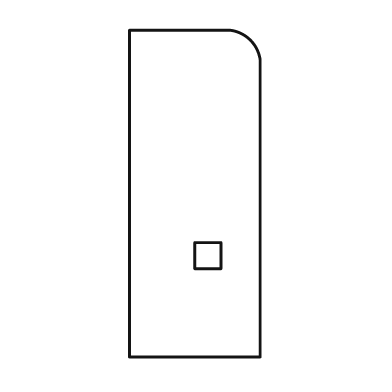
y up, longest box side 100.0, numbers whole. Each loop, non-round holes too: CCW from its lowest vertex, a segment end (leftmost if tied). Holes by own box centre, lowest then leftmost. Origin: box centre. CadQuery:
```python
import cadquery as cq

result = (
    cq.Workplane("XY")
    .moveTo(-20.0, -50.0)
    .lineTo(20.0, -50.0)
    .lineTo(20.0, 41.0)
    .threePointArc((17.0, 47.0), (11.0, 50.0))
    .lineTo(-20.0, 50.0)
    .close()
    .moveTo(0.0, -23.0)
    .lineTo(8.0, -23.0)
    .lineTo(8.0, -15.0)
    .lineTo(0.0, -15.0)
    .close()
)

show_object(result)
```